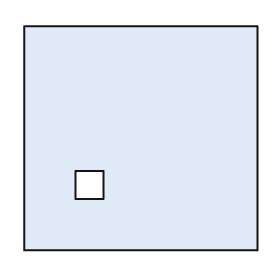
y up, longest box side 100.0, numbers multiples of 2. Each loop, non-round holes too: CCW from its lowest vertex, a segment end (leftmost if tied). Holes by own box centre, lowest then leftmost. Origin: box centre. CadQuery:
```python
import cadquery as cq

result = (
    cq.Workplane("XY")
    .moveTo(-50.0, -48.0)
    .lineTo(50.0, -48.0)
    .lineTo(50.0, 48.0)
    .lineTo(-50.0, 48.0)
    .close()
    .moveTo(-28.0, -26.0)
    .lineTo(-16.0, -26.0)
    .lineTo(-16.0, -14.0)
    .lineTo(-28.0, -14.0)
    .close()
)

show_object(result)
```